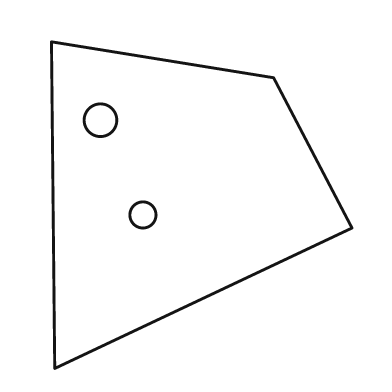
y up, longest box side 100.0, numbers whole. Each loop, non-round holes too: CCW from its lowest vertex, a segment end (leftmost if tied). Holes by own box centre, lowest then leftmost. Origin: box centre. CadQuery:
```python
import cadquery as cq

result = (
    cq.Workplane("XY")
    .moveTo(-45.0, -50.0)
    .lineTo(46.0, -7.0)
    .lineTo(22.0, 39.0)
    .lineTo(-46.0, 50.0)
    .close()
    .moveTo(-18.0, -3.0)
    .circle(4.0)
    .moveTo(-31.0, 26.0)
    .circle(5.0)
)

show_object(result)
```